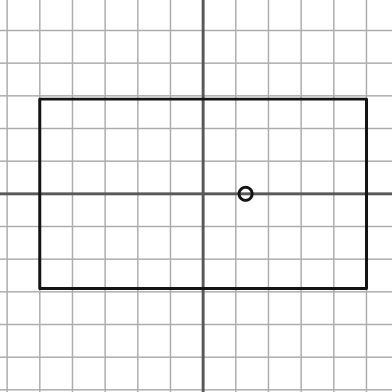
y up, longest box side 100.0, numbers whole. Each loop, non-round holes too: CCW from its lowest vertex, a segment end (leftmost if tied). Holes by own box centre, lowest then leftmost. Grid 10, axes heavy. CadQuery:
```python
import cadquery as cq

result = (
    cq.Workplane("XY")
    .moveTo(-50.0, -29.0)
    .lineTo(50.0, -29.0)
    .lineTo(50.0, 29.0)
    .lineTo(-50.0, 29.0)
    .close()
    .moveTo(13.0, 0.0)
    .circle(2.0)
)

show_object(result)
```